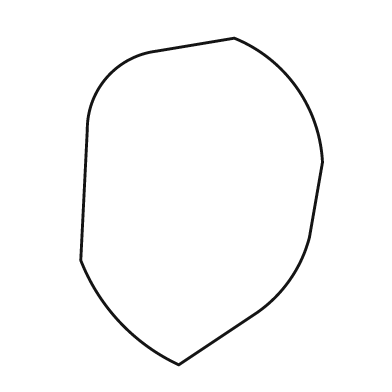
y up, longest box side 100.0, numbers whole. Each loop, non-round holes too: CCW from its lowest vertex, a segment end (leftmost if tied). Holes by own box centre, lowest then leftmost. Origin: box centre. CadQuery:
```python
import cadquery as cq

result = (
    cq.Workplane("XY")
    .moveTo(-7.0, -50.0)
    .lineTo(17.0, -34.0)
    .threePointArc((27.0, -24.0), (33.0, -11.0))
    .lineTo(37.0, 12.0)
    .threePointArc((29.0, 35.0), (10.0, 50.0))
    .lineTo(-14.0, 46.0)
    .threePointArc((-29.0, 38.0), (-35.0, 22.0))
    .lineTo(-37.0, -18.0)
    .threePointArc((-25.0, -37.0), (-7.0, -50.0))
    .close()
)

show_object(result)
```